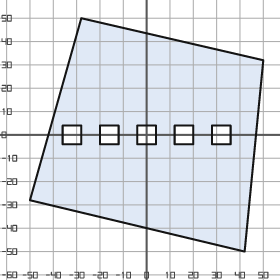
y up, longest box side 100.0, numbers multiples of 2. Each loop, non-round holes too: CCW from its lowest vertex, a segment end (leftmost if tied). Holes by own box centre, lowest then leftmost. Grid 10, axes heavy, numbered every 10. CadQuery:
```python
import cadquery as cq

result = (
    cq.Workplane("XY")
    .moveTo(42.0, -50.0)
    .lineTo(50.0, 32.0)
    .lineTo(-28.0, 50.0)
    .lineTo(-50.0, -28.0)
    .close()
    .moveTo(-36.0, -4.0)
    .lineTo(-28.0, -4.0)
    .lineTo(-28.0, 4.0)
    .lineTo(-36.0, 4.0)
    .close()
    .moveTo(-20.0, -4.0)
    .lineTo(-12.0, -4.0)
    .lineTo(-12.0, 4.0)
    .lineTo(-20.0, 4.0)
    .close()
    .moveTo(-4.0, -4.0)
    .lineTo(4.0, -4.0)
    .lineTo(4.0, 4.0)
    .lineTo(-4.0, 4.0)
    .close()
    .moveTo(12.0, -4.0)
    .lineTo(20.0, -4.0)
    .lineTo(20.0, 4.0)
    .lineTo(12.0, 4.0)
    .close()
    .moveTo(28.0, -4.0)
    .lineTo(36.0, -4.0)
    .lineTo(36.0, 4.0)
    .lineTo(28.0, 4.0)
    .close()
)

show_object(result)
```